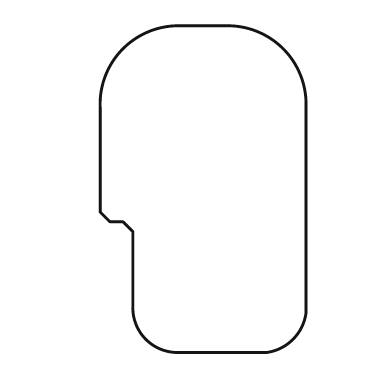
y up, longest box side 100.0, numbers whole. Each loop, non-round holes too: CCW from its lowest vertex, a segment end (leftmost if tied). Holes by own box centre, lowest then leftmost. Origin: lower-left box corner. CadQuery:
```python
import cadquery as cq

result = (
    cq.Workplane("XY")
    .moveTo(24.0, 0.0)
    .lineTo(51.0, 0.0)
    .threePointArc((59.0, 4.0), (63.0, 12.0))
    .lineTo(63.0, 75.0)
    .threePointArc((56.0, 93.0), (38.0, 100.0))
    .lineTo(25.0, 100.0)
    .threePointArc((7.0, 93.0), (0.0, 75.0))
    .lineTo(0.0, 43.0)
    .lineTo(3.0, 40.0)
    .lineTo(7.0, 40.0)
    .lineTo(10.0, 37.0)
    .lineTo(10.0, 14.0)
    .threePointArc((14.0, 4.0), (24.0, 0.0))
    .close()
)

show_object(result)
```